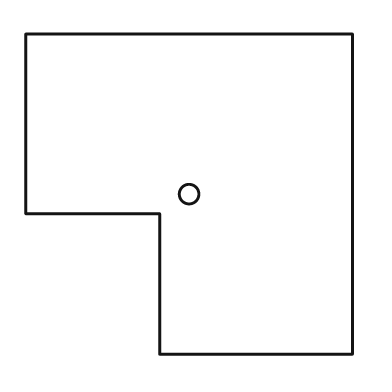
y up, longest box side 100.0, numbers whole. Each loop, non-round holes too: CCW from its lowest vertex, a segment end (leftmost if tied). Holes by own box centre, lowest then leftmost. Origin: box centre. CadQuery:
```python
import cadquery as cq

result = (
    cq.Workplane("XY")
    .moveTo(-9.0, -49.0)
    .lineTo(50.0, -49.0)
    .lineTo(50.0, 49.0)
    .lineTo(-50.0, 49.0)
    .lineTo(-50.0, -6.0)
    .lineTo(-9.0, -6.0)
    .close()
    .moveTo(0.0, 0.0)
    .circle(3.0)
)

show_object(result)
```